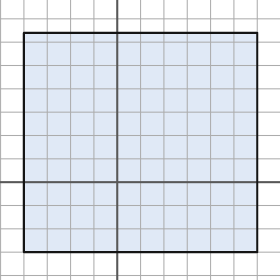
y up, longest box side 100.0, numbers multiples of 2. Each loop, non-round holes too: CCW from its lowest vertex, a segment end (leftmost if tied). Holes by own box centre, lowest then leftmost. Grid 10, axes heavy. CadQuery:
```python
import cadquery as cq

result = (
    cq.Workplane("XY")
    .moveTo(-40.0, -30.0)
    .lineTo(60.0, -30.0)
    .lineTo(60.0, 64.0)
    .lineTo(-40.0, 64.0)
    .close()
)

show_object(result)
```